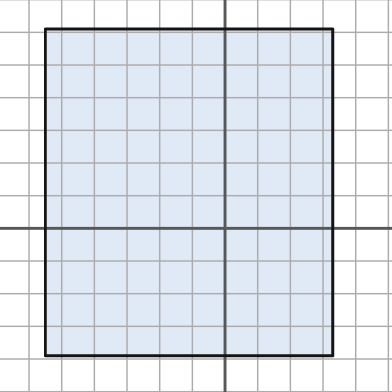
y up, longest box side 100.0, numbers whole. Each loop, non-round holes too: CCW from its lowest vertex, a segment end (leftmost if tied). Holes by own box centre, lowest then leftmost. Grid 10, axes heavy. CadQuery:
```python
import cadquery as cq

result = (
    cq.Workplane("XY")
    .moveTo(-55.0, -39.0)
    .lineTo(33.0, -39.0)
    .lineTo(33.0, 61.0)
    .lineTo(-55.0, 61.0)
    .close()
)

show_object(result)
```